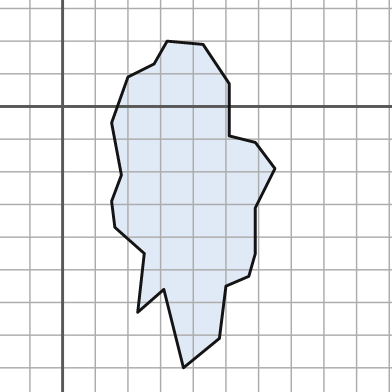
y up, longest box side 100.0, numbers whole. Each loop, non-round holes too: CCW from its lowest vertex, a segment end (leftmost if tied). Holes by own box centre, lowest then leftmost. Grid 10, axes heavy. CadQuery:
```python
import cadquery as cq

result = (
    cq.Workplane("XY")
    .moveTo(37.0, -80.0)
    .lineTo(48.0, -71.0)
    .lineTo(50.0, -55.0)
    .lineTo(57.0, -52.0)
    .lineTo(59.0, -45.0)
    .lineTo(59.0, -31.0)
    .lineTo(65.0, -19.0)
    .lineTo(59.0, -11.0)
    .lineTo(51.0, -9.0)
    .lineTo(51.0, 7.0)
    .lineTo(43.0, 19.0)
    .lineTo(32.0, 20.0)
    .lineTo(28.0, 13.0)
    .lineTo(20.0, 9.0)
    .lineTo(15.0, -5.0)
    .lineTo(18.0, -21.0)
    .lineTo(15.0, -29.0)
    .lineTo(16.0, -37.0)
    .lineTo(25.0, -45.0)
    .lineTo(23.0, -63.0)
    .lineTo(31.0, -56.0)
    .close()
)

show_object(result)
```